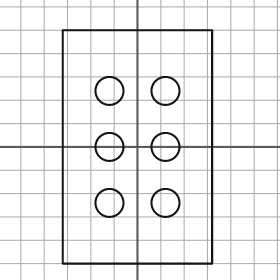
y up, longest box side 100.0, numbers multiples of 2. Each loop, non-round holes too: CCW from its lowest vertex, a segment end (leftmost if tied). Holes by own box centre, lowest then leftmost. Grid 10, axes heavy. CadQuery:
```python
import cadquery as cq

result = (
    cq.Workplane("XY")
    .moveTo(-32.0, -50.0)
    .lineTo(32.0, -50.0)
    .lineTo(32.0, 50.0)
    .lineTo(-32.0, 50.0)
    .close()
    .moveTo(-12.0, -24.0)
    .circle(6.0)
    .moveTo(12.0, -24.0)
    .circle(6.0)
    .moveTo(-12.0, 0.0)
    .circle(6.0)
    .moveTo(12.0, 0.0)
    .circle(6.0)
    .moveTo(-12.0, 24.0)
    .circle(6.0)
    .moveTo(12.0, 24.0)
    .circle(6.0)
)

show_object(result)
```